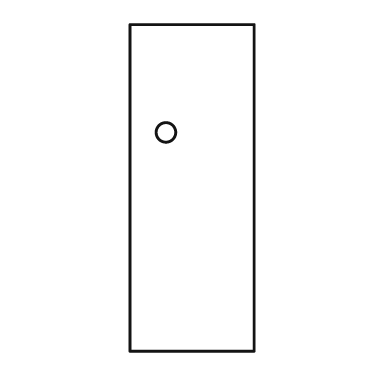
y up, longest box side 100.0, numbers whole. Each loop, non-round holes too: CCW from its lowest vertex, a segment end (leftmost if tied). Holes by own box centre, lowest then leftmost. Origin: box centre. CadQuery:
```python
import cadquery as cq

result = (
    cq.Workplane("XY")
    .moveTo(-19.0, -50.0)
    .lineTo(19.0, -50.0)
    .lineTo(19.0, 50.0)
    .lineTo(-19.0, 50.0)
    .close()
    .moveTo(-8.0, 17.0)
    .circle(3.0)
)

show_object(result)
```